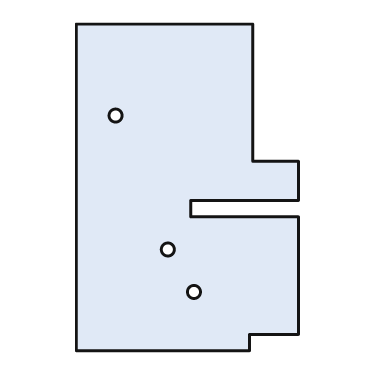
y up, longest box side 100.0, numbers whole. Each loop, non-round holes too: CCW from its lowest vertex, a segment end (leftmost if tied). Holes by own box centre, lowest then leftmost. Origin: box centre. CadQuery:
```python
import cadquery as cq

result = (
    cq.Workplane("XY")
    .moveTo(-34.0, -50.0)
    .lineTo(19.0, -50.0)
    .lineTo(19.0, -45.0)
    .lineTo(34.0, -45.0)
    .lineTo(34.0, -9.0)
    .lineTo(1.0, -9.0)
    .lineTo(1.0, -4.0)
    .lineTo(34.0, -4.0)
    .lineTo(34.0, 8.0)
    .lineTo(20.0, 8.0)
    .lineTo(20.0, 50.0)
    .lineTo(-34.0, 50.0)
    .close()
    .moveTo(2.0, -32.0)
    .circle(2.0)
    .moveTo(-6.0, -19.0)
    .circle(2.0)
    .moveTo(-22.0, 22.0)
    .circle(2.0)
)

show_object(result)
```